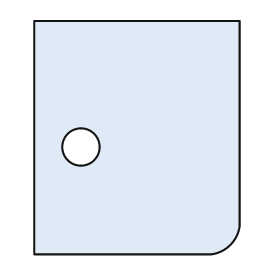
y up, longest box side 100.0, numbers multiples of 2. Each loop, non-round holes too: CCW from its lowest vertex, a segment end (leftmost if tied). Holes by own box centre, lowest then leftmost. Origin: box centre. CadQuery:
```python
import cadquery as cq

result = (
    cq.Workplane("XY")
    .moveTo(-44.0, -50.0)
    .lineTo(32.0, -50.0)
    .threePointArc((40.0, -46.0), (44.0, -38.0))
    .lineTo(44.0, 50.0)
    .lineTo(-44.0, 50.0)
    .close()
    .moveTo(-24.0, -4.0)
    .circle(8.0)
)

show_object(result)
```